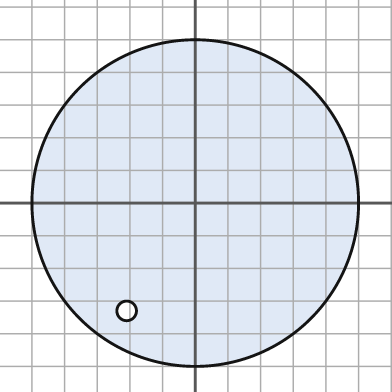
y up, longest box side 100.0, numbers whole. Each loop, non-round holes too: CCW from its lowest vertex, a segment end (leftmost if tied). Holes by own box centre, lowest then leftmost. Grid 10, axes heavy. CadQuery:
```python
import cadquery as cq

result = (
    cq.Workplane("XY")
    .moveTo(0.0, 0.0)
    .circle(50.0)
    .moveTo(-21.0, -33.0)
    .circle(3.0)
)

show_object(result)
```